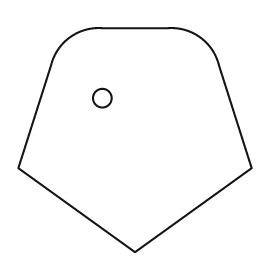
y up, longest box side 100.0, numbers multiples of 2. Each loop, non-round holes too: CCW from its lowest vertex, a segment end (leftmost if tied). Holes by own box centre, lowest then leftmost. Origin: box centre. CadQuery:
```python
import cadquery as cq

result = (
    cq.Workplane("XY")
    .moveTo(0.0, -48.0)
    .lineTo(50.0, -12.0)
    .lineTo(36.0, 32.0)
    .threePointArc((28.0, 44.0), (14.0, 48.0))
    .lineTo(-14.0, 48.0)
    .threePointArc((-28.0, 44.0), (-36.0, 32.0))
    .lineTo(-50.0, -12.0)
    .close()
    .moveTo(-14.0, 18.0)
    .circle(4.0)
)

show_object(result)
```